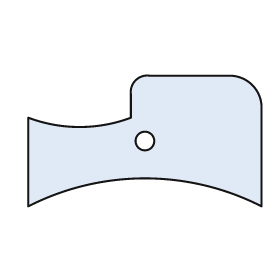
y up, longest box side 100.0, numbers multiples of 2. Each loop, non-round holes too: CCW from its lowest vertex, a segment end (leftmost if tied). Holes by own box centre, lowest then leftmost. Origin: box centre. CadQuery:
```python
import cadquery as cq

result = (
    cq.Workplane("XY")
    .moveTo(-50.0, -28.0)
    .threePointArc((0.0, -16.0), (50.0, -28.0))
    .lineTo(50.0, 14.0)
    .threePointArc((46.0, 24.0), (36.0, 28.0))
    .lineTo(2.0, 28.0)
    .threePointArc((-4.0, 26.0), (-6.0, 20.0))
    .lineTo(-6.0, 10.0)
    .threePointArc((-28.0, 6.0), (-50.0, 10.0))
    .close()
    .moveTo(0.0, 0.0)
    .circle(4.0)
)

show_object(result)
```